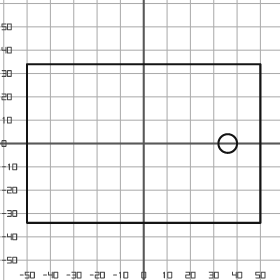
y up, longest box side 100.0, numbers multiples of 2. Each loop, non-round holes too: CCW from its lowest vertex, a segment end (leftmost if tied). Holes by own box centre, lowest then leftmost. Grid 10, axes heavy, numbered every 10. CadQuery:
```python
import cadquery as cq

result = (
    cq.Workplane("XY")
    .moveTo(-50.0, -34.0)
    .lineTo(50.0, -34.0)
    .lineTo(50.0, 34.0)
    .lineTo(-50.0, 34.0)
    .close()
    .moveTo(36.0, 0.0)
    .circle(4.0)
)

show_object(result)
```